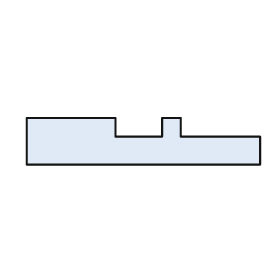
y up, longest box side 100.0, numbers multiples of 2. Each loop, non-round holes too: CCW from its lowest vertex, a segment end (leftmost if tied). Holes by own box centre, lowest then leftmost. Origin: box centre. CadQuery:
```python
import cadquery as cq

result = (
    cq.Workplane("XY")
    .moveTo(-50.0, -10.0)
    .lineTo(50.0, -10.0)
    .lineTo(50.0, 2.0)
    .lineTo(16.0, 2.0)
    .lineTo(16.0, 10.0)
    .lineTo(8.0, 10.0)
    .lineTo(8.0, 2.0)
    .lineTo(-12.0, 2.0)
    .lineTo(-12.0, 10.0)
    .lineTo(-50.0, 10.0)
    .close()
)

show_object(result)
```